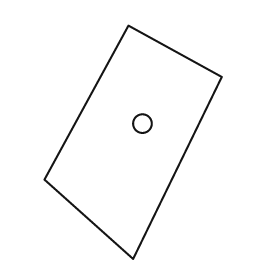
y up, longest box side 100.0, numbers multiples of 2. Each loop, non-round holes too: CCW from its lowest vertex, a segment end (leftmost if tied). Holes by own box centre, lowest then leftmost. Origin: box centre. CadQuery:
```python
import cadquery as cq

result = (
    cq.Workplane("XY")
    .moveTo(0.0, -50.0)
    .lineTo(38.0, 28.0)
    .lineTo(-2.0, 50.0)
    .lineTo(-38.0, -16.0)
    .close()
    .moveTo(4.0, 8.0)
    .circle(4.0)
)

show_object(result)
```